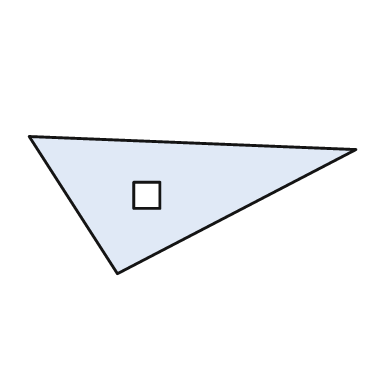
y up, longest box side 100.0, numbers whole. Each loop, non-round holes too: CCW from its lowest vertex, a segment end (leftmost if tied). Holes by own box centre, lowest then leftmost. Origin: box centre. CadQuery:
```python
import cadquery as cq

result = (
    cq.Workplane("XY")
    .moveTo(-23.0, -21.0)
    .lineTo(50.0, 17.0)
    .lineTo(-50.0, 21.0)
    .close()
    .moveTo(-18.0, -1.0)
    .lineTo(-10.0, -1.0)
    .lineTo(-10.0, 7.0)
    .lineTo(-18.0, 7.0)
    .close()
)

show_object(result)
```